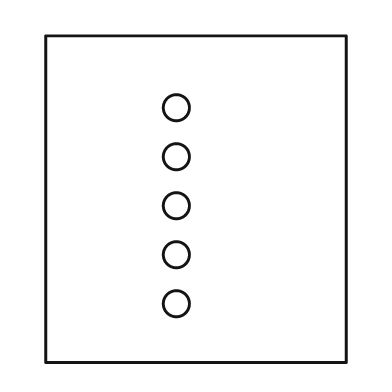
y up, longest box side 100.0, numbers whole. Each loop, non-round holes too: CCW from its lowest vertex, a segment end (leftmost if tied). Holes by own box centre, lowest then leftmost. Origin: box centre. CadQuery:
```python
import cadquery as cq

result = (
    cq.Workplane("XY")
    .moveTo(-46.0, -50.0)
    .lineTo(46.0, -50.0)
    .lineTo(46.0, 50.0)
    .lineTo(-46.0, 50.0)
    .close()
    .moveTo(-6.0, -32.0)
    .circle(4.0)
    .moveTo(-6.0, -17.0)
    .circle(4.0)
    .moveTo(-6.0, -2.0)
    .circle(4.0)
    .moveTo(-6.0, 13.0)
    .circle(4.0)
    .moveTo(-6.0, 28.0)
    .circle(4.0)
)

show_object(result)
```